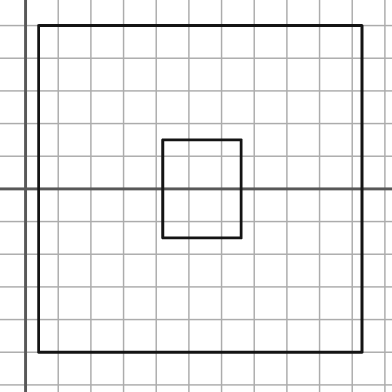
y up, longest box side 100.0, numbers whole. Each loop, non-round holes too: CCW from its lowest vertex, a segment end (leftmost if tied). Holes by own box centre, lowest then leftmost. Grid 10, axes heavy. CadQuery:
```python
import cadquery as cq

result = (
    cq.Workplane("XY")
    .moveTo(4.0, -50.0)
    .lineTo(103.0, -50.0)
    .lineTo(103.0, 50.0)
    .lineTo(4.0, 50.0)
    .close()
    .moveTo(42.0, -15.0)
    .lineTo(66.0, -15.0)
    .lineTo(66.0, 15.0)
    .lineTo(42.0, 15.0)
    .close()
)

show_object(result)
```